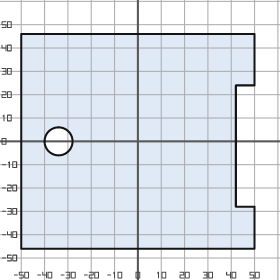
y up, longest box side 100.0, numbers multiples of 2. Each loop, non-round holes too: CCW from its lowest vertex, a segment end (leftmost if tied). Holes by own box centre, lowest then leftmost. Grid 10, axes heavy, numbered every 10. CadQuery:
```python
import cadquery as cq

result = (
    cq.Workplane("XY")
    .moveTo(-50.0, -46.0)
    .lineTo(50.0, -46.0)
    .lineTo(50.0, -28.0)
    .lineTo(42.0, -28.0)
    .lineTo(42.0, 24.0)
    .lineTo(50.0, 24.0)
    .lineTo(50.0, 46.0)
    .lineTo(-50.0, 46.0)
    .close()
    .moveTo(-34.0, 0.0)
    .circle(6.0)
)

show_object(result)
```